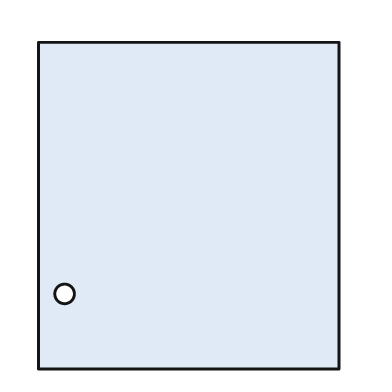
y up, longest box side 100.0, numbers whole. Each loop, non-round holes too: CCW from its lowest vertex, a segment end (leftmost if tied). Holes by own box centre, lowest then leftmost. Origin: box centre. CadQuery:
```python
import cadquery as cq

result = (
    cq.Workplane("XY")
    .moveTo(-46.0, -50.0)
    .lineTo(46.0, -50.0)
    .lineTo(46.0, 50.0)
    .lineTo(-46.0, 50.0)
    .close()
    .moveTo(-38.0, -27.0)
    .circle(3.0)
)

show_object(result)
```